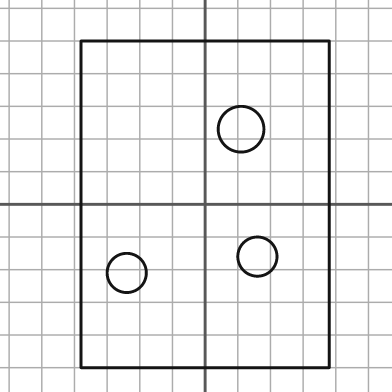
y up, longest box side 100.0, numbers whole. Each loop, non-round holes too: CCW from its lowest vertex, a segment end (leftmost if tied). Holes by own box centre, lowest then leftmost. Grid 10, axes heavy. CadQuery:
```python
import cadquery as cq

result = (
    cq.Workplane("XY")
    .moveTo(-38.0, -50.0)
    .lineTo(38.0, -50.0)
    .lineTo(38.0, 50.0)
    .lineTo(-38.0, 50.0)
    .close()
    .moveTo(-24.0, -21.0)
    .circle(6.0)
    .moveTo(16.0, -16.0)
    .circle(6.0)
    .moveTo(11.0, 23.0)
    .circle(7.0)
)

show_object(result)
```